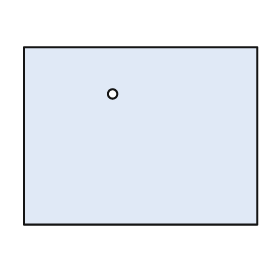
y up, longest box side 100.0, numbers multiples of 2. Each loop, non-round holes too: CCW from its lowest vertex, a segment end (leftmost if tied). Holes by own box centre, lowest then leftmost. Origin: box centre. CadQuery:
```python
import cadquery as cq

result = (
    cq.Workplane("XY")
    .moveTo(-50.0, -38.0)
    .lineTo(50.0, -38.0)
    .lineTo(50.0, 38.0)
    .lineTo(-50.0, 38.0)
    .close()
    .moveTo(-12.0, 18.0)
    .circle(2.0)
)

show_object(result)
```